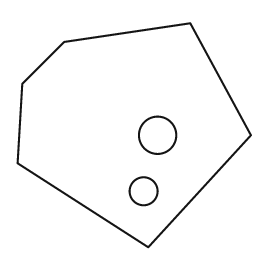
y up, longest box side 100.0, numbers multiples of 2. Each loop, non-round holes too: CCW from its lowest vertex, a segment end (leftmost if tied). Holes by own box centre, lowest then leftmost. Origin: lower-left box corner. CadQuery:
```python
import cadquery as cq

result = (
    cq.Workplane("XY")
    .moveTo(56.0, 0.0)
    .lineTo(100.0, 48.0)
    .lineTo(74.0, 96.0)
    .lineTo(20.0, 88.0)
    .lineTo(2.0, 70.0)
    .lineTo(0.0, 36.0)
    .close()
    .moveTo(54.0, 24.0)
    .circle(6.0)
    .moveTo(60.0, 48.0)
    .circle(8.0)
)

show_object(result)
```